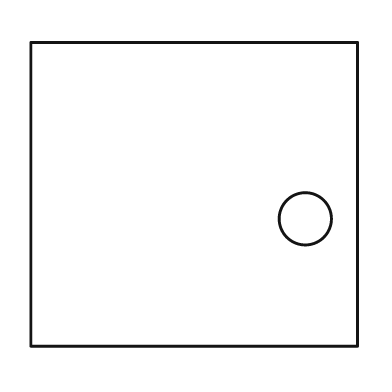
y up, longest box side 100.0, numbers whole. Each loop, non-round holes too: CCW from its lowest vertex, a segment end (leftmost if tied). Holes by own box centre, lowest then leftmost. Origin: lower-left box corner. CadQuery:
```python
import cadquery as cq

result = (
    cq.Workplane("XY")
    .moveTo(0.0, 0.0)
    .lineTo(100.0, 0.0)
    .lineTo(100.0, 93.0)
    .lineTo(0.0, 93.0)
    .close()
    .moveTo(84.0, 39.0)
    .circle(8.0)
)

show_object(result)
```